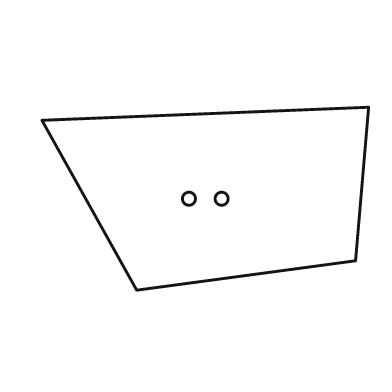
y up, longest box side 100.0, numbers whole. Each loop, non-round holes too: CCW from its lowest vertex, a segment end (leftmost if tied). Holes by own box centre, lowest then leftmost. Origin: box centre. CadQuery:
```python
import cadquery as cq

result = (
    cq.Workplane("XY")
    .moveTo(-21.0, -28.0)
    .lineTo(46.0, -19.0)
    .lineTo(50.0, 28.0)
    .lineTo(-50.0, 24.0)
    .close()
    .moveTo(-5.0, 0.0)
    .circle(2.0)
    .moveTo(5.0, 0.0)
    .circle(2.0)
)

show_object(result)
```